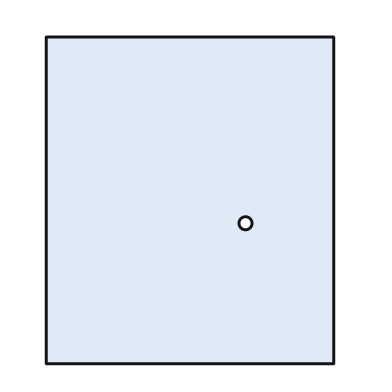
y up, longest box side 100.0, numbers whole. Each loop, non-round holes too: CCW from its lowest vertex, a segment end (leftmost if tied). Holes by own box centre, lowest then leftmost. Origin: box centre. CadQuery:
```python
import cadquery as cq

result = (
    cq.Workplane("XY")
    .moveTo(-44.0, -50.0)
    .lineTo(44.0, -50.0)
    .lineTo(44.0, 50.0)
    .lineTo(-44.0, 50.0)
    .close()
    .moveTo(17.0, -7.0)
    .circle(2.0)
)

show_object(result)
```